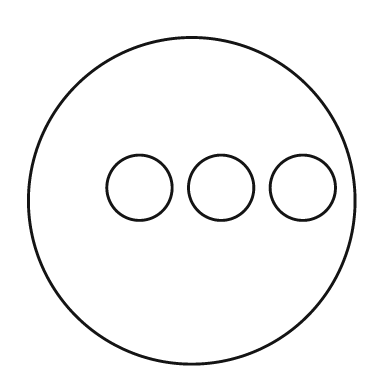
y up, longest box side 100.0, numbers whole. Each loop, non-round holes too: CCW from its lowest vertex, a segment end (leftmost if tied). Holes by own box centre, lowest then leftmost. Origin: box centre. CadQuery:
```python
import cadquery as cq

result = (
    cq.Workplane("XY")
    .moveTo(0.0, 0.0)
    .circle(50.0)
    .moveTo(-16.0, 4.0)
    .circle(10.0)
    .moveTo(9.0, 4.0)
    .circle(10.0)
    .moveTo(34.0, 4.0)
    .circle(10.0)
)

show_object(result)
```